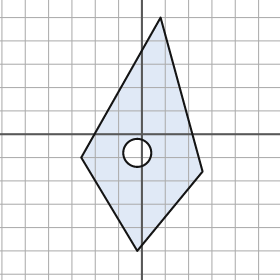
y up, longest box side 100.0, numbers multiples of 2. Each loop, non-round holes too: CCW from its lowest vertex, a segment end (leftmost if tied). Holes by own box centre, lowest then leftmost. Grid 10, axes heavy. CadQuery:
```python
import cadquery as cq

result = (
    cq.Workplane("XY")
    .moveTo(-2.0, -50.0)
    .lineTo(26.0, -16.0)
    .lineTo(8.0, 50.0)
    .lineTo(-26.0, -10.0)
    .close()
    .moveTo(-2.0, -8.0)
    .circle(6.0)
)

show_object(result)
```